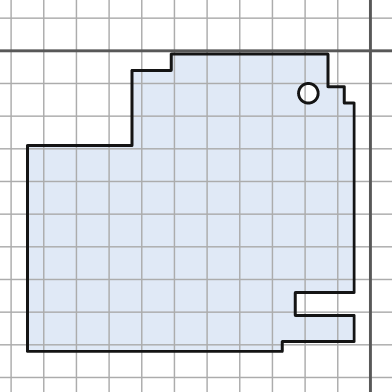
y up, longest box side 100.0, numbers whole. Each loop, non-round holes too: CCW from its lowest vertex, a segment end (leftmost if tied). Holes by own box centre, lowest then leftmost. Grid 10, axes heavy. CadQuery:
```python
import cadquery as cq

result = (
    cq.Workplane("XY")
    .moveTo(-105.0, -92.0)
    .lineTo(-27.0, -92.0)
    .lineTo(-27.0, -89.0)
    .lineTo(-5.0, -89.0)
    .lineTo(-5.0, -81.0)
    .lineTo(-23.0, -81.0)
    .lineTo(-23.0, -74.0)
    .lineTo(-5.0, -74.0)
    .lineTo(-5.0, -16.0)
    .lineTo(-8.0, -16.0)
    .lineTo(-8.0, -11.0)
    .lineTo(-13.0, -11.0)
    .lineTo(-13.0, -1.0)
    .lineTo(-61.0, -1.0)
    .lineTo(-61.0, -6.0)
    .lineTo(-73.0, -6.0)
    .lineTo(-73.0, -29.0)
    .lineTo(-105.0, -29.0)
    .close()
    .moveTo(-19.0, -13.0)
    .circle(3.0)
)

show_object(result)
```